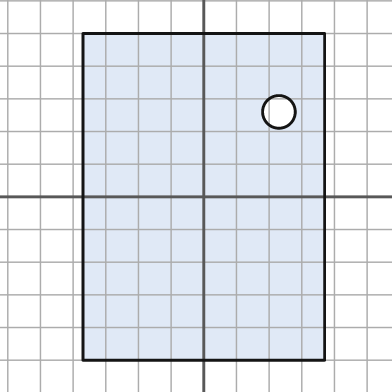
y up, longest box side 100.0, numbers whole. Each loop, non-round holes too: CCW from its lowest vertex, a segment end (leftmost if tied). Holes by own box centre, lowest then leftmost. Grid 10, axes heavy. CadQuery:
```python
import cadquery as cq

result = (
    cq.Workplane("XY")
    .moveTo(-37.0, -50.0)
    .lineTo(37.0, -50.0)
    .lineTo(37.0, 50.0)
    .lineTo(-37.0, 50.0)
    .close()
    .moveTo(23.0, 26.0)
    .circle(5.0)
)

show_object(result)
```